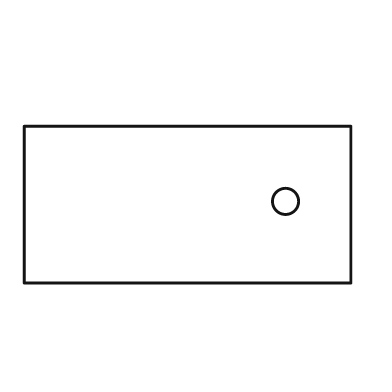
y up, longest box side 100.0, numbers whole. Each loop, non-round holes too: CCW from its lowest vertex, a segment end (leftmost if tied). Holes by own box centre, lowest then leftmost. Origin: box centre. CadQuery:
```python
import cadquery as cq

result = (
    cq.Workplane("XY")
    .moveTo(-50.0, -24.0)
    .lineTo(50.0, -24.0)
    .lineTo(50.0, 24.0)
    .lineTo(-50.0, 24.0)
    .close()
    .moveTo(30.0, 1.0)
    .circle(4.0)
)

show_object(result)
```